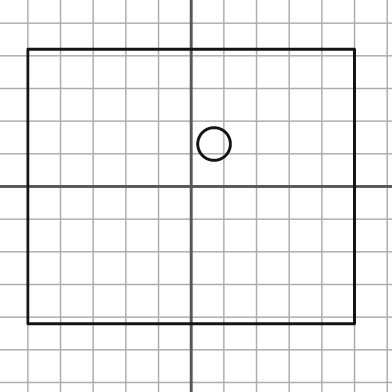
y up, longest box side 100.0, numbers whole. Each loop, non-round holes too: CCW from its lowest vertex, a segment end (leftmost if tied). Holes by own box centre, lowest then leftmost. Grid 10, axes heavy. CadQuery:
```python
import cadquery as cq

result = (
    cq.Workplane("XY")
    .moveTo(-50.0, -42.0)
    .lineTo(50.0, -42.0)
    .lineTo(50.0, 42.0)
    .lineTo(-50.0, 42.0)
    .close()
    .moveTo(7.0, 13.0)
    .circle(5.0)
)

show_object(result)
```